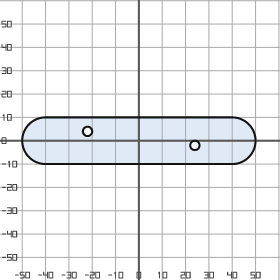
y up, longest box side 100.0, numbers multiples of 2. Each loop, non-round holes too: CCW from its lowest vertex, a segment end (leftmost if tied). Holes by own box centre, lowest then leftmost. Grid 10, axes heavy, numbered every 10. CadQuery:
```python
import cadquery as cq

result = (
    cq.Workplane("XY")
    .moveTo(-40.0, -10.0)
    .lineTo(40.0, -10.0)
    .threePointArc((50.0, 0.0), (40.0, 10.0))
    .lineTo(-40.0, 10.0)
    .threePointArc((-50.0, 0.0), (-40.0, -10.0))
    .close()
    .moveTo(24.0, -2.0)
    .circle(2.0)
    .moveTo(-22.0, 4.0)
    .circle(2.0)
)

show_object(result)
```